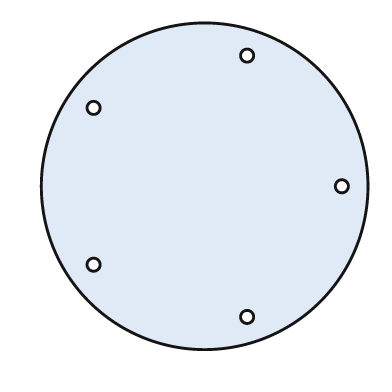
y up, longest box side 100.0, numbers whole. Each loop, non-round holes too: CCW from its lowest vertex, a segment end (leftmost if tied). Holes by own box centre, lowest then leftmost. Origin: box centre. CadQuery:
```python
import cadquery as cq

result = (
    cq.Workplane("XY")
    .moveTo(0.0, 0.0)
    .circle(50.0)
    .moveTo(13.0, -40.0)
    .circle(2.0)
    .moveTo(-34.0, -24.0)
    .circle(2.0)
    .moveTo(42.0, 0.0)
    .circle(2.0)
    .moveTo(-34.0, 24.0)
    .circle(2.0)
    .moveTo(13.0, 40.0)
    .circle(2.0)
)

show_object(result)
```